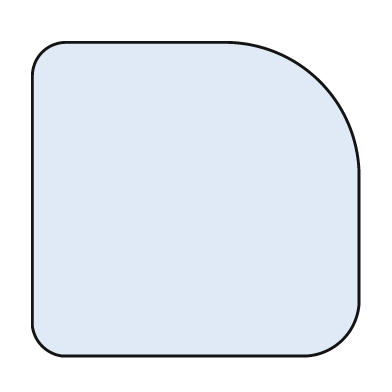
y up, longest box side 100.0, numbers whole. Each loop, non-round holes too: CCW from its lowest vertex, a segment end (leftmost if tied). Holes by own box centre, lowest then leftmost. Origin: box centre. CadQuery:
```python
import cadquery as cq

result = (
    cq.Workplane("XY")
    .moveTo(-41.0, -48.0)
    .lineTo(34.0, -48.0)
    .threePointArc((45.0, -43.0), (50.0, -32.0))
    .lineTo(50.0, 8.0)
    .threePointArc((38.0, 36.0), (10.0, 48.0))
    .lineTo(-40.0, 48.0)
    .threePointArc((-47.0, 45.0), (-50.0, 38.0))
    .lineTo(-50.0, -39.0)
    .threePointArc((-47.0, -45.0), (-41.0, -48.0))
    .close()
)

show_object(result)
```